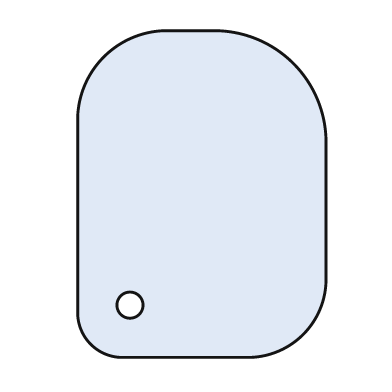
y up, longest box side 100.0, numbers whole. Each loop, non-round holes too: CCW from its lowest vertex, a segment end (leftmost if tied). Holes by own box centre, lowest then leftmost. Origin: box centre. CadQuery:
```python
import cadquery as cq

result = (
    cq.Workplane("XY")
    .moveTo(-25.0, -50.0)
    .lineTo(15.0, -50.0)
    .threePointArc((31.0, -43.0), (38.0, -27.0))
    .lineTo(38.0, 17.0)
    .threePointArc((28.0, 40.0), (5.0, 50.0))
    .lineTo(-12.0, 50.0)
    .threePointArc((-30.0, 42.0), (-38.0, 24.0))
    .lineTo(-38.0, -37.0)
    .threePointArc((-34.0, -46.0), (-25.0, -50.0))
    .close()
    .moveTo(-22.0, -34.0)
    .circle(4.0)
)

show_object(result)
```